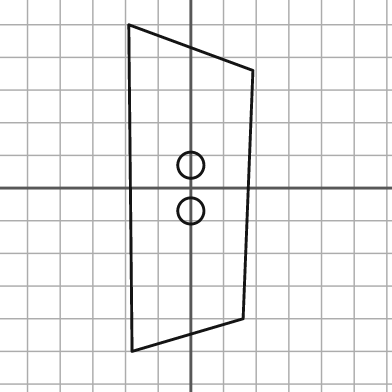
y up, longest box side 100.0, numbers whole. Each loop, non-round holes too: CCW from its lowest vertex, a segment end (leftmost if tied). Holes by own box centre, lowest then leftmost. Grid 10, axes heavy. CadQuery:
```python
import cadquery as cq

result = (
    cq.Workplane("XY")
    .moveTo(-18.0, -50.0)
    .lineTo(16.0, -40.0)
    .lineTo(19.0, 36.0)
    .lineTo(-19.0, 50.0)
    .close()
    .moveTo(0.0, -7.0)
    .circle(4.0)
    .moveTo(0.0, 7.0)
    .circle(4.0)
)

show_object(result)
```